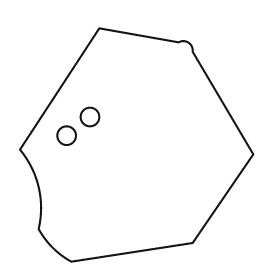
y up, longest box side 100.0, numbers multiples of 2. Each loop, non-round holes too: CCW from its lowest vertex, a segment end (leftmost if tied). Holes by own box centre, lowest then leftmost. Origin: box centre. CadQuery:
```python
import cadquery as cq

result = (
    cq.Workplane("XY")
    .moveTo(-28.0, -50.0)
    .lineTo(24.0, -42.0)
    .lineTo(50.0, -4.0)
    .lineTo(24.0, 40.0)
    .threePointArc((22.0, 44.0), (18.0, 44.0))
    .lineTo(-16.0, 50.0)
    .lineTo(-50.0, -2.0)
    .threePointArc((-42.0, -18.0), (-42.0, -36.0))
    .threePointArc((-36.0, -44.0), (-28.0, -50.0))
    .close()
    .moveTo(-30.0, 4.0)
    .circle(4.0)
    .moveTo(-20.0, 12.0)
    .circle(4.0)
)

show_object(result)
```